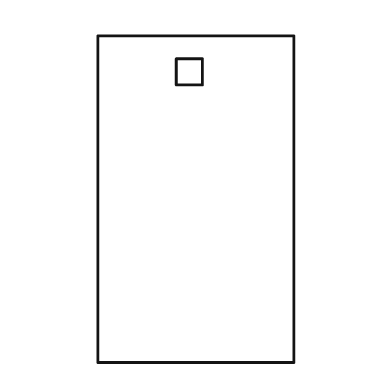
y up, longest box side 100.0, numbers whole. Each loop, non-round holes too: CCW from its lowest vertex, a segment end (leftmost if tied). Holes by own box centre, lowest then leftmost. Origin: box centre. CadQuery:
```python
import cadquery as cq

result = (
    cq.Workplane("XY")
    .moveTo(-30.0, -50.0)
    .lineTo(30.0, -50.0)
    .lineTo(30.0, 50.0)
    .lineTo(-30.0, 50.0)
    .close()
    .moveTo(-6.0, 35.0)
    .lineTo(2.0, 35.0)
    .lineTo(2.0, 43.0)
    .lineTo(-6.0, 43.0)
    .close()
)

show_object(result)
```